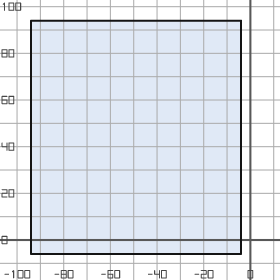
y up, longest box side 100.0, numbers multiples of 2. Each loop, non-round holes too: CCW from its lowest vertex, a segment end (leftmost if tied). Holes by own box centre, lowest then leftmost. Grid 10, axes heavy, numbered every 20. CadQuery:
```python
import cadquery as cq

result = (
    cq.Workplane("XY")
    .moveTo(-94.0, -6.0)
    .lineTo(-4.0, -6.0)
    .lineTo(-4.0, 94.0)
    .lineTo(-94.0, 94.0)
    .close()
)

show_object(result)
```